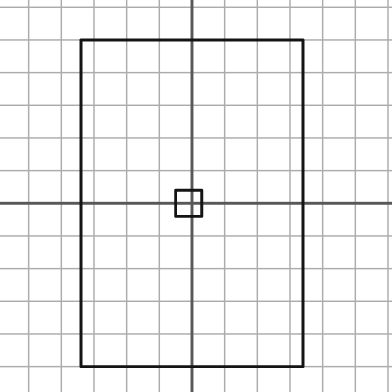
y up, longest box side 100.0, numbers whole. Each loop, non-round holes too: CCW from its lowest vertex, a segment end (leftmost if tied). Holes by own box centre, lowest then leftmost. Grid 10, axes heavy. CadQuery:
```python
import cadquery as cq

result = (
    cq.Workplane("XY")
    .moveTo(-34.0, -50.0)
    .lineTo(34.0, -50.0)
    .lineTo(34.0, 50.0)
    .lineTo(-34.0, 50.0)
    .close()
    .moveTo(-5.0, -4.0)
    .lineTo(3.0, -4.0)
    .lineTo(3.0, 4.0)
    .lineTo(-5.0, 4.0)
    .close()
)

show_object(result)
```